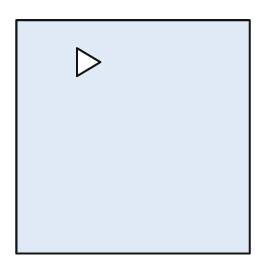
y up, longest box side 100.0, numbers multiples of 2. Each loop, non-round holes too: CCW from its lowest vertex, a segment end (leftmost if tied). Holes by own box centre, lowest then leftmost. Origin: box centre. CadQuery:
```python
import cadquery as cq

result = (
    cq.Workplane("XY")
    .moveTo(-50.0, -50.0)
    .lineTo(50.0, -50.0)
    .lineTo(50.0, 50.0)
    .lineTo(-50.0, 50.0)
    .close()
    .moveTo(-24.0, 26.0)
    .lineTo(-14.0, 32.0)
    .lineTo(-24.0, 38.0)
    .close()
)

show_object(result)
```